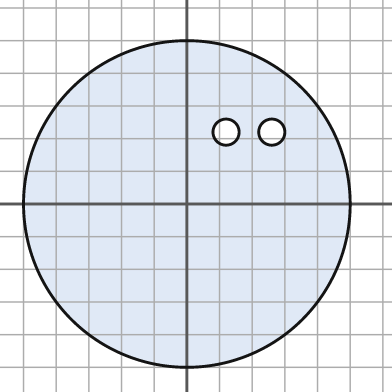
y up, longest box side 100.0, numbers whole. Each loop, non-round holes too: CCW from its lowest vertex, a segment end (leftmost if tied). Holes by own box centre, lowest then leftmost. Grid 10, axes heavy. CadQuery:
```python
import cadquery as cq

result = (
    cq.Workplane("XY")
    .moveTo(0.0, 0.0)
    .circle(50.0)
    .moveTo(12.0, 22.0)
    .circle(4.0)
    .moveTo(26.0, 22.0)
    .circle(4.0)
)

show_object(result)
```